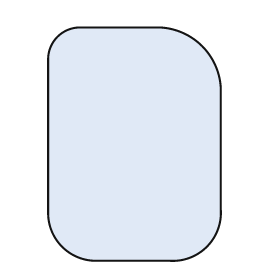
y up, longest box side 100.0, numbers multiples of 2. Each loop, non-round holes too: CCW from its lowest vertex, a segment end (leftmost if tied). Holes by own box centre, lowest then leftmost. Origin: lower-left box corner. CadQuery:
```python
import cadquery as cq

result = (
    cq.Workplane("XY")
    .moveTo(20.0, 0.0)
    .lineTo(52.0, 0.0)
    .threePointArc((68.0, 6.0), (74.0, 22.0))
    .lineTo(74.0, 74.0)
    .threePointArc((66.0, 92.0), (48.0, 100.0))
    .lineTo(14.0, 100.0)
    .threePointArc((4.0, 96.0), (0.0, 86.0))
    .lineTo(0.0, 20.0)
    .threePointArc((6.0, 6.0), (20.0, 0.0))
    .close()
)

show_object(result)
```